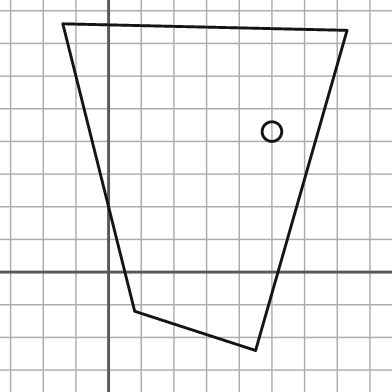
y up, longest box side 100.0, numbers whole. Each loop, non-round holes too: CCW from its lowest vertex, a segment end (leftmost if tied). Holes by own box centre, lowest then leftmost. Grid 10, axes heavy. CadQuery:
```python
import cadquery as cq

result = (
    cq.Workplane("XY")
    .moveTo(45.0, -24.0)
    .lineTo(73.0, 74.0)
    .lineTo(-14.0, 76.0)
    .lineTo(8.0, -12.0)
    .close()
    .moveTo(50.0, 43.0)
    .circle(3.0)
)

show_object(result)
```